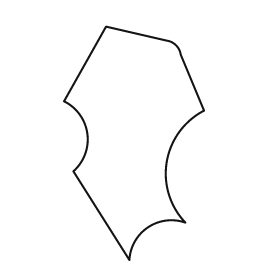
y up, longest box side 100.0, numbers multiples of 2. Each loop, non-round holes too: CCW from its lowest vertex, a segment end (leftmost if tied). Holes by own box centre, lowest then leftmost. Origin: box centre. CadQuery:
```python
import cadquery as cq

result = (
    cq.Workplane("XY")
    .moveTo(-2.0, -50.0)
    .threePointArc((6.0, -36.0), (22.0, -34.0))
    .threePointArc((14.0, -8.0), (30.0, 14.0))
    .lineTo(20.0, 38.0)
    .threePointArc((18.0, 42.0), (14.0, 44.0))
    .lineTo(-12.0, 50.0)
    .lineTo(-30.0, 18.0)
    .threePointArc((-20.0, 4.0), (-26.0, -12.0))
    .close()
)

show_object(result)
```